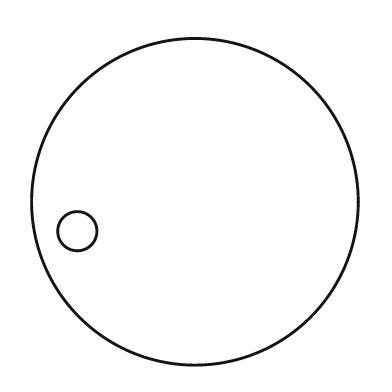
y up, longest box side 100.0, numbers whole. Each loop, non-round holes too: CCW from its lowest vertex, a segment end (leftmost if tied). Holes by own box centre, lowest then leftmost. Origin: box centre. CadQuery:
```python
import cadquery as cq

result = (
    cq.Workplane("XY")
    .moveTo(0.0, 0.0)
    .circle(50.0)
    .moveTo(-36.0, -9.0)
    .circle(6.0)
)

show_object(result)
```